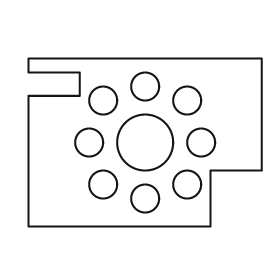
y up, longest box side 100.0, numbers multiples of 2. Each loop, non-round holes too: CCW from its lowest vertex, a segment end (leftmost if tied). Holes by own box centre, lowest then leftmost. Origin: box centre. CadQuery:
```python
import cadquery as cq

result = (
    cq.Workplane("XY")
    .moveTo(-50.0, -36.0)
    .lineTo(28.0, -36.0)
    .lineTo(28.0, -12.0)
    .lineTo(50.0, -12.0)
    .lineTo(50.0, 36.0)
    .lineTo(-50.0, 36.0)
    .lineTo(-50.0, 30.0)
    .lineTo(-28.0, 30.0)
    .lineTo(-28.0, 20.0)
    .lineTo(-50.0, 20.0)
    .close()
    .moveTo(0.0, -24.0)
    .circle(6.0)
    .moveTo(-18.0, -18.0)
    .circle(6.0)
    .moveTo(18.0, -18.0)
    .circle(6.0)
    .moveTo(-24.0, 0.0)
    .circle(6.0)
    .moveTo(0.0, 0.0)
    .circle(12.0)
    .moveTo(24.0, 0.0)
    .circle(6.0)
    .moveTo(-18.0, 18.0)
    .circle(6.0)
    .moveTo(18.0, 18.0)
    .circle(6.0)
    .moveTo(0.0, 24.0)
    .circle(6.0)
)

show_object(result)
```